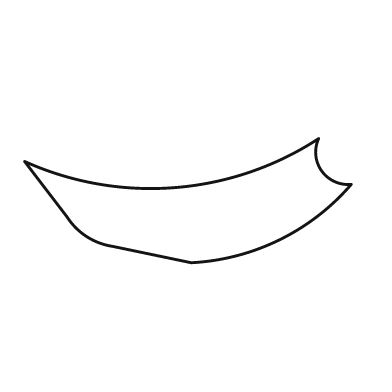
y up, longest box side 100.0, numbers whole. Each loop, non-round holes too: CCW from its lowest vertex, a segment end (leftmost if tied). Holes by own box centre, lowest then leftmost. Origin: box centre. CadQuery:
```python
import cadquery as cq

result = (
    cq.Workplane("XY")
    .moveTo(1.0, -19.0)
    .threePointArc((28.0, -12.0), (50.0, 5.0))
    .threePointArc((41.0, 9.0), (40.0, 19.0))
    .threePointArc((-4.0, 4.0), (-50.0, 12.0))
    .lineTo(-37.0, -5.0)
    .threePointArc((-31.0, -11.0), (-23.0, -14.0))
    .close()
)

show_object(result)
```